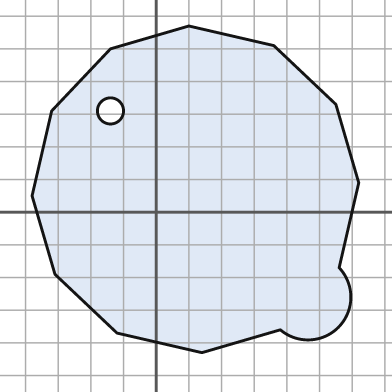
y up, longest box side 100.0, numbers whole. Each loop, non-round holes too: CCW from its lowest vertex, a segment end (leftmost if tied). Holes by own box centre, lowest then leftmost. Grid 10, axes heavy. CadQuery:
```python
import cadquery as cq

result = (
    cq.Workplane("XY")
    .moveTo(14.0, -43.0)
    .lineTo(38.0, -36.0)
    .threePointArc((56.0, -35.0), (56.0, -17.0))
    .lineTo(62.0, 9.0)
    .lineTo(55.0, 33.0)
    .lineTo(36.0, 51.0)
    .lineTo(10.0, 57.0)
    .lineTo(-14.0, 50.0)
    .lineTo(-32.0, 31.0)
    .lineTo(-38.0, 5.0)
    .lineTo(-31.0, -19.0)
    .lineTo(-12.0, -37.0)
    .close()
    .moveTo(-14.0, 31.0)
    .circle(4.0)
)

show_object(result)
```